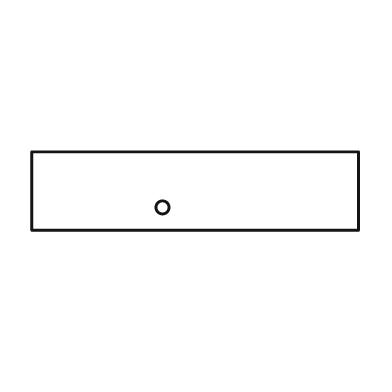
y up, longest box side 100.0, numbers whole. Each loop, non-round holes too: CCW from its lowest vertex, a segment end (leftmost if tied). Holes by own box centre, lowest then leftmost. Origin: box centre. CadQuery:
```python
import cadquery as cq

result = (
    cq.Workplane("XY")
    .moveTo(-50.0, -12.0)
    .lineTo(50.0, -12.0)
    .lineTo(50.0, 12.0)
    .lineTo(-50.0, 12.0)
    .close()
    .moveTo(-10.0, -5.0)
    .circle(2.0)
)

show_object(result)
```